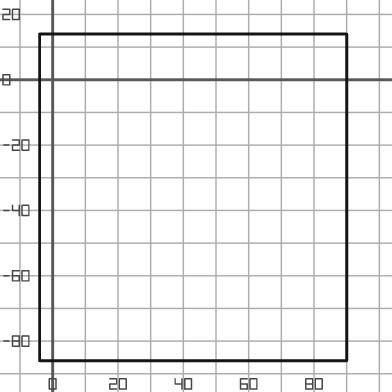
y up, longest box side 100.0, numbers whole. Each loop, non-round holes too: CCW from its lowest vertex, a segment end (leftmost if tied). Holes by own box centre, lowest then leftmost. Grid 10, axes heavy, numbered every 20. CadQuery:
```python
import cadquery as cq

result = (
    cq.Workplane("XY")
    .moveTo(-4.0, -86.0)
    .lineTo(90.0, -86.0)
    .lineTo(90.0, 14.0)
    .lineTo(-4.0, 14.0)
    .close()
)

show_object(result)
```